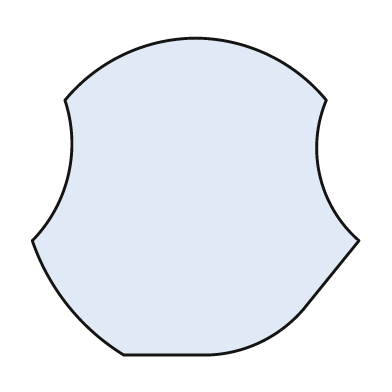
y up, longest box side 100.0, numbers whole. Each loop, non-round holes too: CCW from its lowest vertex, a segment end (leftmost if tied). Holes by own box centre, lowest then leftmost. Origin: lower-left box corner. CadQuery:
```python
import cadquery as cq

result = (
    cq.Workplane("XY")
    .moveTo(28.0, 0.0)
    .lineTo(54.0, 0.0)
    .threePointArc((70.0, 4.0), (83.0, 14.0))
    .lineTo(100.0, 35.0)
    .threePointArc((88.0, 55.0), (90.0, 78.0))
    .threePointArc((72.0, 92.0), (50.0, 97.0))
    .threePointArc((28.0, 92.0), (10.0, 78.0))
    .threePointArc((11.0, 55.0), (0.0, 35.0))
    .threePointArc((11.0, 15.0), (28.0, 0.0))
    .close()
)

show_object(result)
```